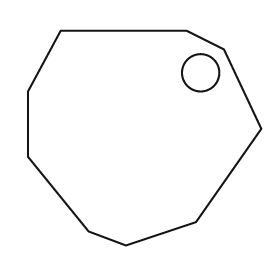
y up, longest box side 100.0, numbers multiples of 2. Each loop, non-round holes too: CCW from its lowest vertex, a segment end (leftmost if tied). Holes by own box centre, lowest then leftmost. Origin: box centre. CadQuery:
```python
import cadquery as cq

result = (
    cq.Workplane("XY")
    .moveTo(-8.0, -46.0)
    .lineTo(22.0, -36.0)
    .lineTo(50.0, 4.0)
    .lineTo(34.0, 38.0)
    .lineTo(18.0, 46.0)
    .lineTo(-36.0, 46.0)
    .lineTo(-50.0, 20.0)
    .lineTo(-50.0, -8.0)
    .lineTo(-24.0, -40.0)
    .close()
    .moveTo(24.0, 28.0)
    .circle(8.0)
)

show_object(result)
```